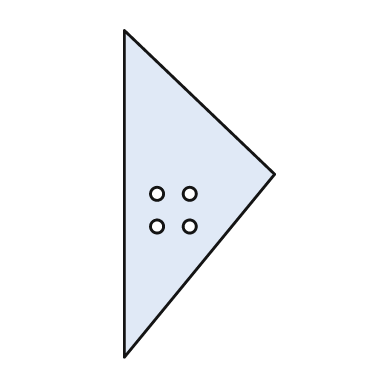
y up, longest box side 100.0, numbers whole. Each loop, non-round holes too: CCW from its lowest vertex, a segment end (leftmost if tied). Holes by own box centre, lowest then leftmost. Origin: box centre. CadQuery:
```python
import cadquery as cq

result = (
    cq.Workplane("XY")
    .moveTo(-23.0, -50.0)
    .lineTo(23.0, 6.0)
    .lineTo(-23.0, 50.0)
    .close()
    .moveTo(-13.0, -10.0)
    .circle(2.0)
    .moveTo(-3.0, -10.0)
    .circle(2.0)
    .moveTo(-13.0, 0.0)
    .circle(2.0)
    .moveTo(-3.0, 0.0)
    .circle(2.0)
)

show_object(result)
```